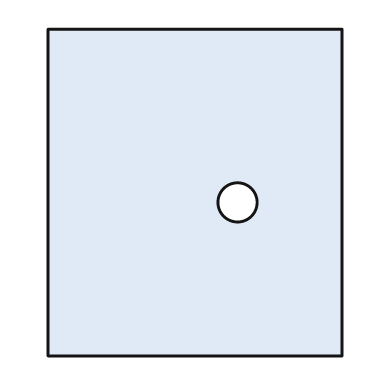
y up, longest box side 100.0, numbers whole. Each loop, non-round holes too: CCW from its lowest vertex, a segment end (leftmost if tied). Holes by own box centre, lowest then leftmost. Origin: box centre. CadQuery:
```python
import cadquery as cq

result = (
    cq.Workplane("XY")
    .moveTo(-45.0, -50.0)
    .lineTo(45.0, -50.0)
    .lineTo(45.0, 50.0)
    .lineTo(-45.0, 50.0)
    .close()
    .moveTo(13.0, -3.0)
    .circle(6.0)
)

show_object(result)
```